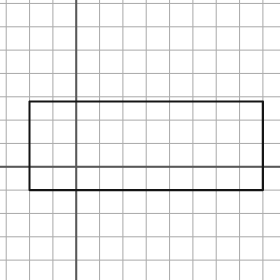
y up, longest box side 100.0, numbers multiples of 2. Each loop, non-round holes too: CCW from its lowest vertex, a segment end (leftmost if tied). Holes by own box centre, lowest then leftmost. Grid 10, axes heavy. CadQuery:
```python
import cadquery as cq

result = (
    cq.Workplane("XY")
    .moveTo(-20.0, -10.0)
    .lineTo(80.0, -10.0)
    .lineTo(80.0, 28.0)
    .lineTo(-20.0, 28.0)
    .close()
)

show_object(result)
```